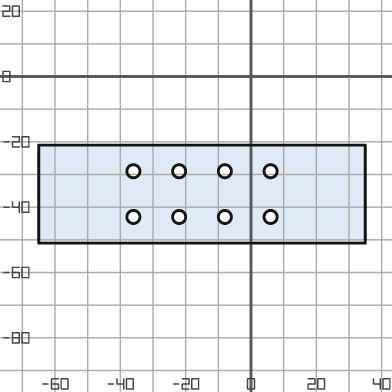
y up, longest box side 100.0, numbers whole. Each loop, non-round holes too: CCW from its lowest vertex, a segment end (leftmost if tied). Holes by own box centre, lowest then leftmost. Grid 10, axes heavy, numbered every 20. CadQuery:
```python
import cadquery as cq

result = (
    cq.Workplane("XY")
    .moveTo(-65.0, -51.0)
    .lineTo(35.0, -51.0)
    .lineTo(35.0, -21.0)
    .lineTo(-65.0, -21.0)
    .close()
    .moveTo(-36.0, -43.0)
    .circle(2.0)
    .moveTo(-22.0, -43.0)
    .circle(2.0)
    .moveTo(-8.0, -43.0)
    .circle(2.0)
    .moveTo(6.0, -43.0)
    .circle(2.0)
    .moveTo(-36.0, -29.0)
    .circle(2.0)
    .moveTo(-22.0, -29.0)
    .circle(2.0)
    .moveTo(-8.0, -29.0)
    .circle(2.0)
    .moveTo(6.0, -29.0)
    .circle(2.0)
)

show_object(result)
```